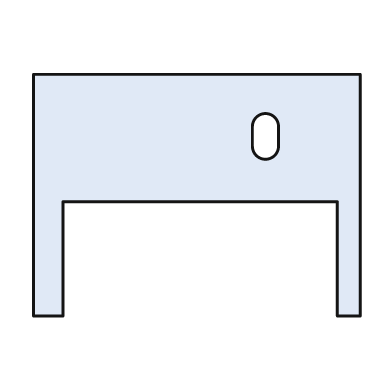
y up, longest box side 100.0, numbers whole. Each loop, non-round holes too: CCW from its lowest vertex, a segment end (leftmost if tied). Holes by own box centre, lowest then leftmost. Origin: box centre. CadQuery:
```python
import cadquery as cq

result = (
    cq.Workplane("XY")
    .moveTo(-50.0, -37.0)
    .lineTo(-41.0, -37.0)
    .lineTo(-41.0, -2.0)
    .lineTo(43.0, -2.0)
    .lineTo(43.0, -37.0)
    .lineTo(50.0, -37.0)
    .lineTo(50.0, 37.0)
    .lineTo(-50.0, 37.0)
    .close()
    .moveTo(17.0, 15.0)
    .threePointArc((21.0, 11.0), (25.0, 15.0))
    .lineTo(25.0, 21.0)
    .threePointArc((21.0, 25.0), (17.0, 21.0))
    .close()
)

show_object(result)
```